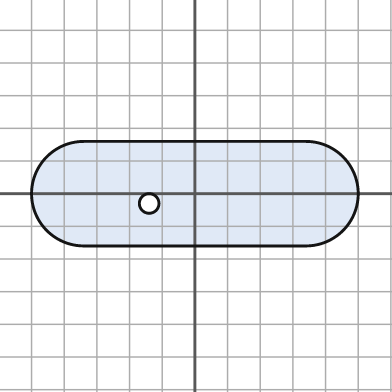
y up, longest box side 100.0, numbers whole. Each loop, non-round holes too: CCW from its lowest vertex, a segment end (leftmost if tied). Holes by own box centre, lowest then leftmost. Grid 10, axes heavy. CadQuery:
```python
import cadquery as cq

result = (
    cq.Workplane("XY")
    .moveTo(-34.0, -16.0)
    .lineTo(34.0, -16.0)
    .threePointArc((50.0, 0.0), (34.0, 16.0))
    .lineTo(-34.0, 16.0)
    .threePointArc((-50.0, 0.0), (-34.0, -16.0))
    .close()
    .moveTo(-14.0, -3.0)
    .circle(3.0)
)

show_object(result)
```